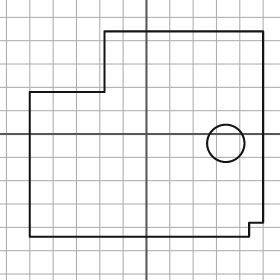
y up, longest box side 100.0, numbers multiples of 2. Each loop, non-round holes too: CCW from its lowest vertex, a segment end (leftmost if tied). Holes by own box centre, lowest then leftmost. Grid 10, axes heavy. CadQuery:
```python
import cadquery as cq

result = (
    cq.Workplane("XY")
    .moveTo(-50.0, -44.0)
    .lineTo(44.0, -44.0)
    .lineTo(44.0, -38.0)
    .lineTo(50.0, -38.0)
    .lineTo(50.0, 44.0)
    .lineTo(-18.0, 44.0)
    .lineTo(-18.0, 18.0)
    .lineTo(-50.0, 18.0)
    .close()
    .moveTo(34.0, -4.0)
    .circle(8.0)
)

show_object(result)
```